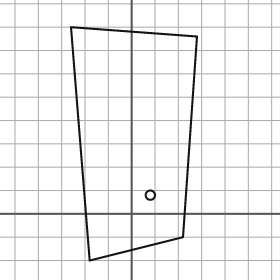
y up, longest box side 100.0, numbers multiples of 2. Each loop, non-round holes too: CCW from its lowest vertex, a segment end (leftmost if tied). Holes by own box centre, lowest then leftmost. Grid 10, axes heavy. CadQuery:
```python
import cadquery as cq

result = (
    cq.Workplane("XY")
    .moveTo(-18.0, -20.0)
    .lineTo(22.0, -10.0)
    .lineTo(28.0, 76.0)
    .lineTo(-26.0, 80.0)
    .close()
    .moveTo(8.0, 8.0)
    .circle(2.0)
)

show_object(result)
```